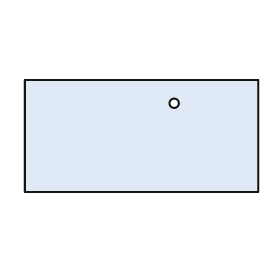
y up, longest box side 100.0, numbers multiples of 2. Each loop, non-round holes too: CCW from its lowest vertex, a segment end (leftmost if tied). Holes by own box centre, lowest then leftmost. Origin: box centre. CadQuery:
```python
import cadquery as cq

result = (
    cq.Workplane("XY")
    .moveTo(-50.0, -24.0)
    .lineTo(50.0, -24.0)
    .lineTo(50.0, 24.0)
    .lineTo(-50.0, 24.0)
    .close()
    .moveTo(14.0, 14.0)
    .circle(2.0)
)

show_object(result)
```